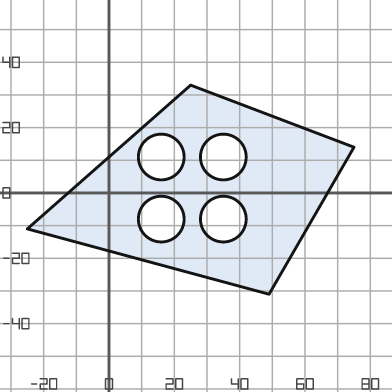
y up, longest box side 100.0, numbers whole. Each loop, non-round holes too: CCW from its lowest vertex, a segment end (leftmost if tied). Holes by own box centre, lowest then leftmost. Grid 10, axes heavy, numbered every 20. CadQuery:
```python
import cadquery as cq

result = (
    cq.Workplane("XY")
    .moveTo(49.0, -31.0)
    .lineTo(75.0, 14.0)
    .lineTo(25.0, 33.0)
    .lineTo(-25.0, -11.0)
    .close()
    .moveTo(16.0, -8.0)
    .circle(7.0)
    .moveTo(35.0, -8.0)
    .circle(7.0)
    .moveTo(16.0, 11.0)
    .circle(7.0)
    .moveTo(35.0, 11.0)
    .circle(7.0)
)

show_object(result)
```